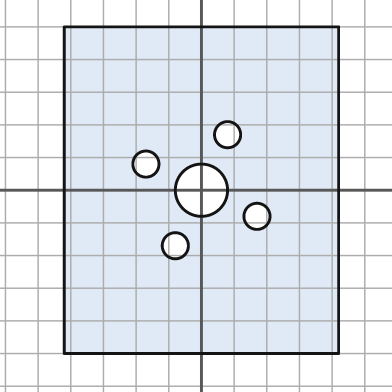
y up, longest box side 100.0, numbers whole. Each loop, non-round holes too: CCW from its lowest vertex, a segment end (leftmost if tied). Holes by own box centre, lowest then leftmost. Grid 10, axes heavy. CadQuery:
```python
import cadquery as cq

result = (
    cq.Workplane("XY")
    .moveTo(-42.0, -50.0)
    .lineTo(42.0, -50.0)
    .lineTo(42.0, 50.0)
    .lineTo(-42.0, 50.0)
    .close()
    .moveTo(-8.0, -17.0)
    .circle(4.0)
    .moveTo(17.0, -8.0)
    .circle(4.0)
    .moveTo(0.0, 0.0)
    .circle(8.0)
    .moveTo(-17.0, 8.0)
    .circle(4.0)
    .moveTo(8.0, 17.0)
    .circle(4.0)
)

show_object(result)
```